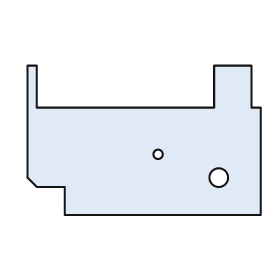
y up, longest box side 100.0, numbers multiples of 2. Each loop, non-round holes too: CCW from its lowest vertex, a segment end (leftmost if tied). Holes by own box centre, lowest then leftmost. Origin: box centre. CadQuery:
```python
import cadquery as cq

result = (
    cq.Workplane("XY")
    .moveTo(-34.0, -32.0)
    .lineTo(50.0, -32.0)
    .lineTo(50.0, 14.0)
    .lineTo(46.0, 14.0)
    .lineTo(46.0, 32.0)
    .lineTo(30.0, 32.0)
    .lineTo(30.0, 14.0)
    .lineTo(-46.0, 14.0)
    .lineTo(-46.0, 32.0)
    .lineTo(-50.0, 32.0)
    .lineTo(-50.0, -16.0)
    .lineTo(-46.0, -20.0)
    .lineTo(-34.0, -20.0)
    .close()
    .moveTo(32.0, -16.0)
    .circle(4.0)
    .moveTo(6.0, -6.0)
    .circle(2.0)
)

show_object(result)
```